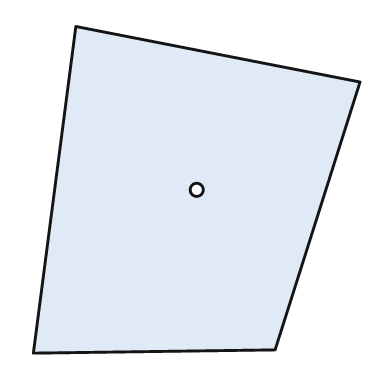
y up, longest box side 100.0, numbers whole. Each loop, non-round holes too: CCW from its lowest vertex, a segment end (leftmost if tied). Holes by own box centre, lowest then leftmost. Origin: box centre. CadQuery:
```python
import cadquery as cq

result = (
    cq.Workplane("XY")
    .moveTo(-50.0, -50.0)
    .lineTo(24.0, -49.0)
    .lineTo(50.0, 33.0)
    .lineTo(-37.0, 50.0)
    .close()
    .moveTo(0.0, 0.0)
    .circle(2.0)
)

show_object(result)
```